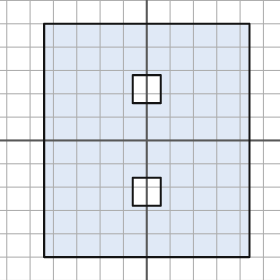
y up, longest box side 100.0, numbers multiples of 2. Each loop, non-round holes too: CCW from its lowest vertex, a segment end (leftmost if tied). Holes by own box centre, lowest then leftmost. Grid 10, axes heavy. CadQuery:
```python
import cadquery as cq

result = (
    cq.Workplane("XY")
    .moveTo(-44.0, -50.0)
    .lineTo(44.0, -50.0)
    .lineTo(44.0, 50.0)
    .lineTo(-44.0, 50.0)
    .close()
    .moveTo(-6.0, -28.0)
    .lineTo(6.0, -28.0)
    .lineTo(6.0, -16.0)
    .lineTo(-6.0, -16.0)
    .close()
    .moveTo(-6.0, 16.0)
    .lineTo(6.0, 16.0)
    .lineTo(6.0, 28.0)
    .lineTo(-6.0, 28.0)
    .close()
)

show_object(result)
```